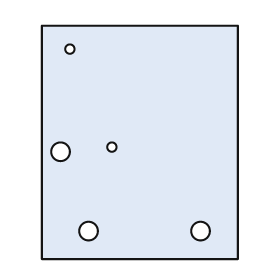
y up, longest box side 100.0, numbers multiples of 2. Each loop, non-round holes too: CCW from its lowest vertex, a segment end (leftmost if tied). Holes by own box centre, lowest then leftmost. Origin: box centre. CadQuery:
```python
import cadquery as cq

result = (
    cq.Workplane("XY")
    .moveTo(-42.0, -50.0)
    .lineTo(42.0, -50.0)
    .lineTo(42.0, 50.0)
    .lineTo(-42.0, 50.0)
    .close()
    .moveTo(-22.0, -38.0)
    .circle(4.0)
    .moveTo(26.0, -38.0)
    .circle(4.0)
    .moveTo(-34.0, -4.0)
    .circle(4.0)
    .moveTo(-12.0, -2.0)
    .circle(2.0)
    .moveTo(-30.0, 40.0)
    .circle(2.0)
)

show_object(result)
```